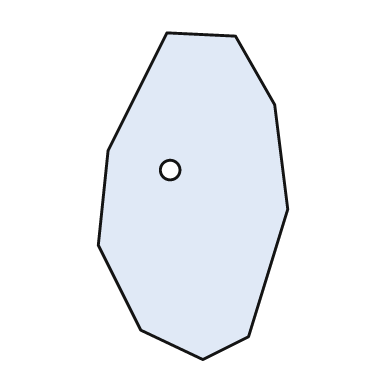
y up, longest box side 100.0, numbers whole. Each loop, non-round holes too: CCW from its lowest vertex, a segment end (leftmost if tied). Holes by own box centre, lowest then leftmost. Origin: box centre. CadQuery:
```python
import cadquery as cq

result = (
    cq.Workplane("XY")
    .moveTo(3.0, -50.0)
    .lineTo(17.0, -43.0)
    .lineTo(29.0, -4.0)
    .lineTo(25.0, 28.0)
    .lineTo(13.0, 49.0)
    .lineTo(-8.0, 50.0)
    .lineTo(-26.0, 14.0)
    .lineTo(-29.0, -15.0)
    .lineTo(-16.0, -41.0)
    .close()
    .moveTo(-7.0, 8.0)
    .circle(3.0)
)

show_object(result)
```